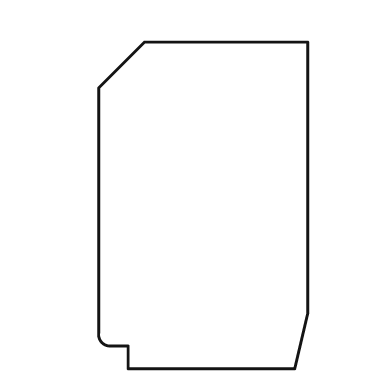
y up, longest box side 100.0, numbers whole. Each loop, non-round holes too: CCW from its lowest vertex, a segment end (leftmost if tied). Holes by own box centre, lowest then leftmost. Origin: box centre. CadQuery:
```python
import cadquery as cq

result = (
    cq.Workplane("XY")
    .moveTo(-23.0, -50.0)
    .lineTo(28.0, -50.0)
    .lineTo(32.0, -33.0)
    .lineTo(32.0, 50.0)
    .lineTo(-18.0, 50.0)
    .lineTo(-32.0, 36.0)
    .lineTo(-32.0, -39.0)
    .threePointArc((-31.0, -42.0), (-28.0, -43.0))
    .lineTo(-23.0, -43.0)
    .close()
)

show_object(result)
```